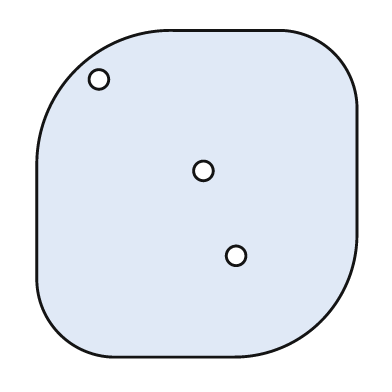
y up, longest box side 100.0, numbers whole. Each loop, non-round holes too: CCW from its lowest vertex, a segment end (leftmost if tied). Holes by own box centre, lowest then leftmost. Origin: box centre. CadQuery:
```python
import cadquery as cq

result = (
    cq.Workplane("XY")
    .moveTo(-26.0, -50.0)
    .lineTo(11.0, -50.0)
    .threePointArc((38.0, -39.0), (49.0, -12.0))
    .lineTo(49.0, 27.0)
    .threePointArc((42.0, 43.0), (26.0, 50.0))
    .lineTo(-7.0, 50.0)
    .threePointArc((-37.0, 38.0), (-49.0, 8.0))
    .lineTo(-49.0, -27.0)
    .threePointArc((-42.0, -43.0), (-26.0, -50.0))
    .close()
    .moveTo(12.0, -19.0)
    .circle(3.0)
    .moveTo(2.0, 7.0)
    .circle(3.0)
    .moveTo(-30.0, 35.0)
    .circle(3.0)
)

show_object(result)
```